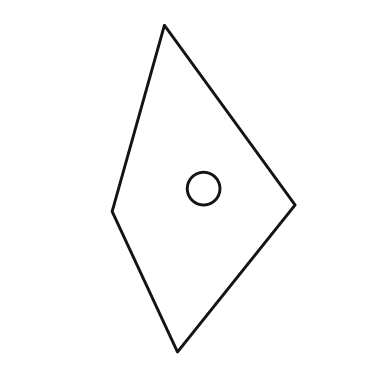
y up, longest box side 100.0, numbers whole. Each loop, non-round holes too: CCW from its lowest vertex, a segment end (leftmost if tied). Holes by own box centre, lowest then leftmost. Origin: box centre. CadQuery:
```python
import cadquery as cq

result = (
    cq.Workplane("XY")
    .moveTo(-8.0, -50.0)
    .lineTo(28.0, -5.0)
    .lineTo(-12.0, 50.0)
    .lineTo(-28.0, -7.0)
    .close()
    .moveTo(0.0, 0.0)
    .circle(5.0)
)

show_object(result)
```